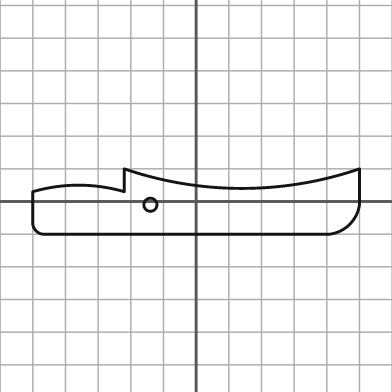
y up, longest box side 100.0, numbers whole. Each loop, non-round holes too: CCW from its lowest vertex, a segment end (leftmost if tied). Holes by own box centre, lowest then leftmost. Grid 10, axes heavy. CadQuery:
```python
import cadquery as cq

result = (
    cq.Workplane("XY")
    .moveTo(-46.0, -10.0)
    .lineTo(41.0, -10.0)
    .threePointArc((47.0, -7.0), (50.0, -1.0))
    .lineTo(50.0, 10.0)
    .threePointArc((14.0, 4.0), (-22.0, 10.0))
    .lineTo(-22.0, 3.0)
    .threePointArc((-36.0, 5.0), (-50.0, 3.0))
    .lineTo(-50.0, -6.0)
    .threePointArc((-49.0, -9.0), (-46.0, -10.0))
    .close()
    .moveTo(-14.0, -1.0)
    .circle(2.0)
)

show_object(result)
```